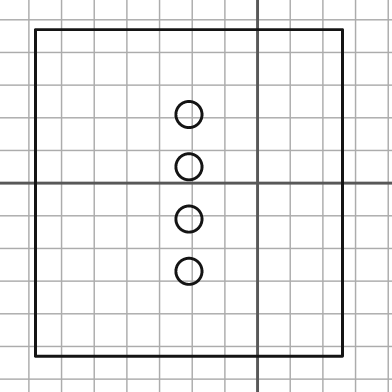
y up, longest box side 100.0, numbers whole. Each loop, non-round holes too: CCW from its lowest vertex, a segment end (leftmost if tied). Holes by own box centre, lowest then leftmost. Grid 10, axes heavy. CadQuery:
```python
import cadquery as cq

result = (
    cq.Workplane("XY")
    .moveTo(-68.0, -53.0)
    .lineTo(26.0, -53.0)
    .lineTo(26.0, 47.0)
    .lineTo(-68.0, 47.0)
    .close()
    .moveTo(-21.0, -27.0)
    .circle(4.0)
    .moveTo(-21.0, -11.0)
    .circle(4.0)
    .moveTo(-21.0, 5.0)
    .circle(4.0)
    .moveTo(-21.0, 21.0)
    .circle(4.0)
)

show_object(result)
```